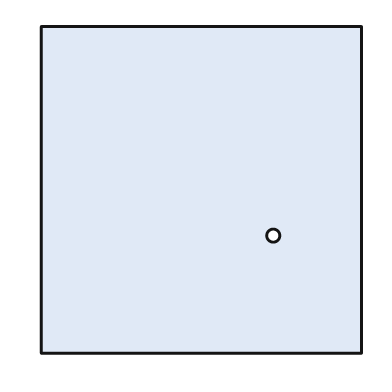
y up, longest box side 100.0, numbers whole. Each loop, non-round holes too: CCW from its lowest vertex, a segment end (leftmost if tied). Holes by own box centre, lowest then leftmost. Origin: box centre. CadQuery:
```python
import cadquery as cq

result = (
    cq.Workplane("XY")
    .moveTo(-49.0, -50.0)
    .lineTo(49.0, -50.0)
    .lineTo(49.0, 50.0)
    .lineTo(-49.0, 50.0)
    .close()
    .moveTo(22.0, -14.0)
    .circle(2.0)
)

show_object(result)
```